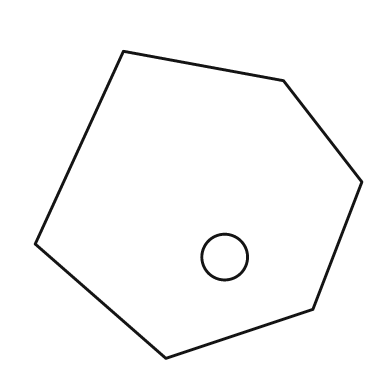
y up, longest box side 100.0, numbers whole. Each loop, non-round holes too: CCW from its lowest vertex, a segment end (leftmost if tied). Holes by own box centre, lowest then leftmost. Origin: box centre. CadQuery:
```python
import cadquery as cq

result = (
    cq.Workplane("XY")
    .moveTo(-10.0, -47.0)
    .lineTo(35.0, -32.0)
    .lineTo(50.0, 7.0)
    .lineTo(26.0, 38.0)
    .lineTo(-23.0, 47.0)
    .lineTo(-50.0, -12.0)
    .close()
    .moveTo(8.0, -16.0)
    .circle(7.0)
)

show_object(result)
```